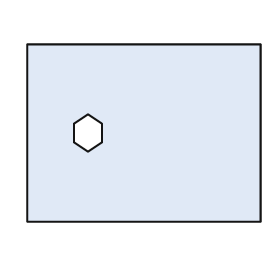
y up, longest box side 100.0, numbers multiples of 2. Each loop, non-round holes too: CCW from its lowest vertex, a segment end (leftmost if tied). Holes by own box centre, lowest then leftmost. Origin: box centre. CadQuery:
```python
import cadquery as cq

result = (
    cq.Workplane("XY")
    .moveTo(-50.0, -38.0)
    .lineTo(50.0, -38.0)
    .lineTo(50.0, 38.0)
    .lineTo(-50.0, 38.0)
    .close()
    .moveTo(-24.0, -8.0)
    .lineTo(-18.0, -4.0)
    .lineTo(-18.0, 4.0)
    .lineTo(-24.0, 8.0)
    .lineTo(-30.0, 4.0)
    .lineTo(-30.0, -4.0)
    .close()
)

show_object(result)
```